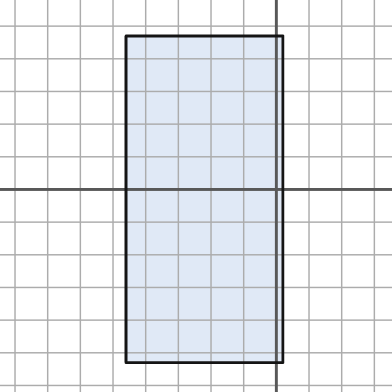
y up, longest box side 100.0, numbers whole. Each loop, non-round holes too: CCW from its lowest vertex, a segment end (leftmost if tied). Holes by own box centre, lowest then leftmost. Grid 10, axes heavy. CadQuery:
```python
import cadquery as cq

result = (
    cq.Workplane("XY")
    .moveTo(-46.0, -53.0)
    .lineTo(2.0, -53.0)
    .lineTo(2.0, 47.0)
    .lineTo(-46.0, 47.0)
    .close()
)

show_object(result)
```